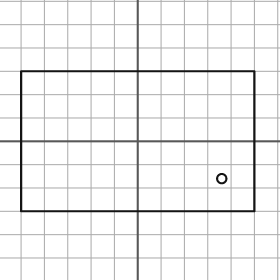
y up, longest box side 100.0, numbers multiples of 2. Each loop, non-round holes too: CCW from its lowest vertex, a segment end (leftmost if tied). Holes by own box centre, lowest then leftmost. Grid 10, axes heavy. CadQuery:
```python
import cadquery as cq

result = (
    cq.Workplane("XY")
    .moveTo(-50.0, -30.0)
    .lineTo(50.0, -30.0)
    .lineTo(50.0, 30.0)
    .lineTo(-50.0, 30.0)
    .close()
    .moveTo(36.0, -16.0)
    .circle(2.0)
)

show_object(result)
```